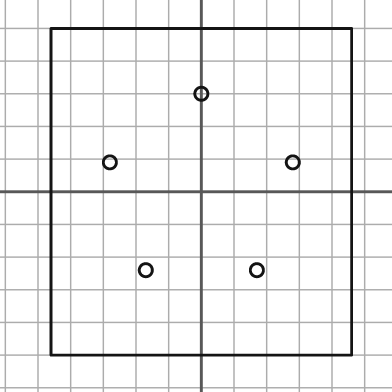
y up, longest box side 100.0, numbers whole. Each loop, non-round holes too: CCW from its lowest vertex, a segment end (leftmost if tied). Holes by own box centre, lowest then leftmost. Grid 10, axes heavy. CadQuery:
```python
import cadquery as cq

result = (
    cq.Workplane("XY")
    .moveTo(-46.0, -50.0)
    .lineTo(46.0, -50.0)
    .lineTo(46.0, 50.0)
    .lineTo(-46.0, 50.0)
    .close()
    .moveTo(-17.0, -24.0)
    .circle(2.0)
    .moveTo(17.0, -24.0)
    .circle(2.0)
    .moveTo(-28.0, 9.0)
    .circle(2.0)
    .moveTo(28.0, 9.0)
    .circle(2.0)
    .moveTo(0.0, 30.0)
    .circle(2.0)
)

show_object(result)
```